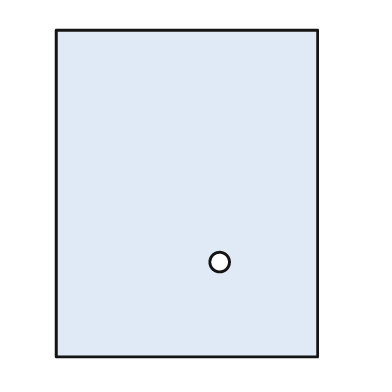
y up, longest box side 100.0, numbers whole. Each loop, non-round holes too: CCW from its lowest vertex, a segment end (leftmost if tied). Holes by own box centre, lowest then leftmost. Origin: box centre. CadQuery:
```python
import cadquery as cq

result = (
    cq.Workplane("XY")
    .moveTo(-40.0, -50.0)
    .lineTo(40.0, -50.0)
    .lineTo(40.0, 50.0)
    .lineTo(-40.0, 50.0)
    .close()
    .moveTo(10.0, -21.0)
    .circle(3.0)
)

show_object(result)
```